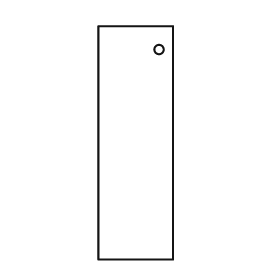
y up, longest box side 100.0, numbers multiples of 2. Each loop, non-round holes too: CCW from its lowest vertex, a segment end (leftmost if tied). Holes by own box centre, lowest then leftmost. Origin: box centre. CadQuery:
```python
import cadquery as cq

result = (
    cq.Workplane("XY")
    .moveTo(-16.0, -50.0)
    .lineTo(16.0, -50.0)
    .lineTo(16.0, 50.0)
    .lineTo(-16.0, 50.0)
    .close()
    .moveTo(10.0, 40.0)
    .circle(2.0)
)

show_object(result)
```